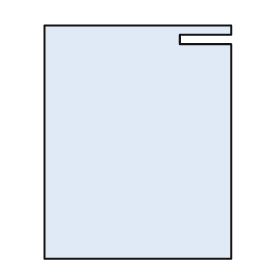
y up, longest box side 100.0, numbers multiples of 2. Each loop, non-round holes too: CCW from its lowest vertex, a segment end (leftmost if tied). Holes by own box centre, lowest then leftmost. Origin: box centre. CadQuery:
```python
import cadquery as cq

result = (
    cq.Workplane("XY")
    .moveTo(-40.0, -50.0)
    .lineTo(40.0, -50.0)
    .lineTo(40.0, 42.0)
    .lineTo(18.0, 42.0)
    .lineTo(18.0, 46.0)
    .lineTo(40.0, 46.0)
    .lineTo(40.0, 50.0)
    .lineTo(-40.0, 50.0)
    .close()
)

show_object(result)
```